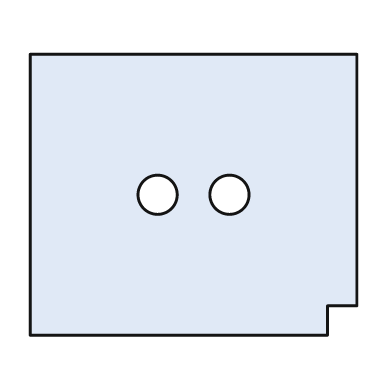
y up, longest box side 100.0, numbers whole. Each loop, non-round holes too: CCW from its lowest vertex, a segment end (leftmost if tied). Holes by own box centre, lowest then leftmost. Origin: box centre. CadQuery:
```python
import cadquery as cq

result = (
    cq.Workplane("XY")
    .moveTo(-50.0, -43.0)
    .lineTo(41.0, -43.0)
    .lineTo(41.0, -34.0)
    .lineTo(50.0, -34.0)
    .lineTo(50.0, 43.0)
    .lineTo(-50.0, 43.0)
    .close()
    .moveTo(-11.0, 0.0)
    .circle(6.0)
    .moveTo(11.0, 0.0)
    .circle(6.0)
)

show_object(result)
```